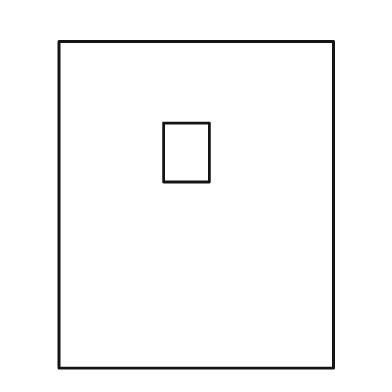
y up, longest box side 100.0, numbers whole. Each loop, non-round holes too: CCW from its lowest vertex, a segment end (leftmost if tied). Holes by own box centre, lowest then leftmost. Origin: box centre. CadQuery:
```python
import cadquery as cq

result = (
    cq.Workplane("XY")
    .moveTo(-42.0, -50.0)
    .lineTo(42.0, -50.0)
    .lineTo(42.0, 50.0)
    .lineTo(-42.0, 50.0)
    .close()
    .moveTo(-10.0, 7.0)
    .lineTo(4.0, 7.0)
    .lineTo(4.0, 25.0)
    .lineTo(-10.0, 25.0)
    .close()
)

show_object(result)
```